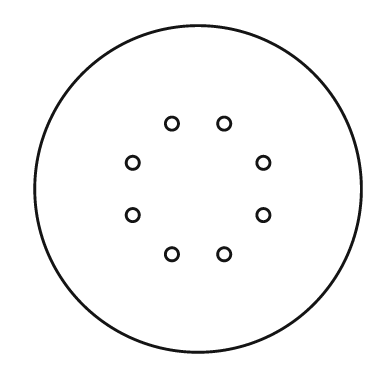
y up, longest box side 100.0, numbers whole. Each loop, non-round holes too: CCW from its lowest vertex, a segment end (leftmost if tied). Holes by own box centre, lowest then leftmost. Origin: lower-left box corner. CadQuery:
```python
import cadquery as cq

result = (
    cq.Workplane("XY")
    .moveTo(50.0, 50.0)
    .circle(50.0)
    .moveTo(42.0, 30.0)
    .circle(2.0)
    .moveTo(58.0, 30.0)
    .circle(2.0)
    .moveTo(30.0, 42.0)
    .circle(2.0)
    .moveTo(70.0, 42.0)
    .circle(2.0)
    .moveTo(30.0, 58.0)
    .circle(2.0)
    .moveTo(70.0, 58.0)
    .circle(2.0)
    .moveTo(42.0, 70.0)
    .circle(2.0)
    .moveTo(58.0, 70.0)
    .circle(2.0)
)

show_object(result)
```